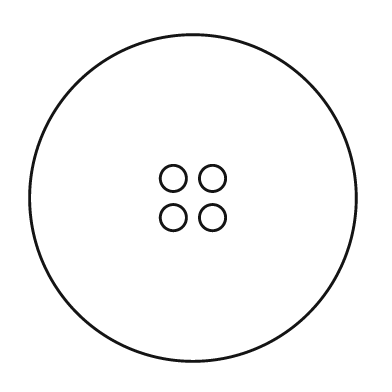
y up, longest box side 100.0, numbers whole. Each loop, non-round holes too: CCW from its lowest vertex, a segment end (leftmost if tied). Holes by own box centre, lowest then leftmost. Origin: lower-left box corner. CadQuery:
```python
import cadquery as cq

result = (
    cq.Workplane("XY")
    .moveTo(50.0, 50.0)
    .circle(50.0)
    .moveTo(44.0, 44.0)
    .circle(4.0)
    .moveTo(56.0, 44.0)
    .circle(4.0)
    .moveTo(44.0, 56.0)
    .circle(4.0)
    .moveTo(56.0, 56.0)
    .circle(4.0)
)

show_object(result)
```